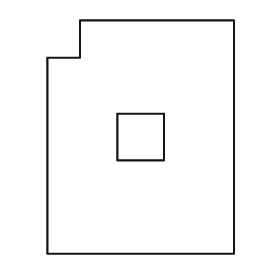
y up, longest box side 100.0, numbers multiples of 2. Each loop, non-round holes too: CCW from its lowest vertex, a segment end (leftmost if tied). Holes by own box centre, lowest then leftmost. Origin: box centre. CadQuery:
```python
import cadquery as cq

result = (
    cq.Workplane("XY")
    .moveTo(-40.0, -50.0)
    .lineTo(40.0, -50.0)
    .lineTo(40.0, 50.0)
    .lineTo(-26.0, 50.0)
    .lineTo(-26.0, 34.0)
    .lineTo(-40.0, 34.0)
    .close()
    .moveTo(-10.0, -10.0)
    .lineTo(10.0, -10.0)
    .lineTo(10.0, 10.0)
    .lineTo(-10.0, 10.0)
    .close()
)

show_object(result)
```